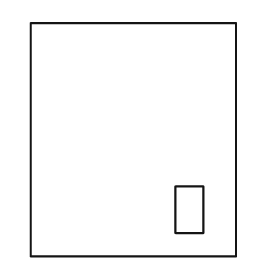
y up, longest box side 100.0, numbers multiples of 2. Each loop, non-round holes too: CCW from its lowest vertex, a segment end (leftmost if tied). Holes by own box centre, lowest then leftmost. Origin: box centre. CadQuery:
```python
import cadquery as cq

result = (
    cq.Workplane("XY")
    .moveTo(-44.0, -50.0)
    .lineTo(44.0, -50.0)
    .lineTo(44.0, 50.0)
    .lineTo(-44.0, 50.0)
    .close()
    .moveTo(18.0, -40.0)
    .lineTo(30.0, -40.0)
    .lineTo(30.0, -20.0)
    .lineTo(18.0, -20.0)
    .close()
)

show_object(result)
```